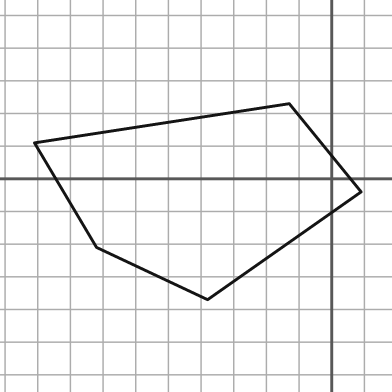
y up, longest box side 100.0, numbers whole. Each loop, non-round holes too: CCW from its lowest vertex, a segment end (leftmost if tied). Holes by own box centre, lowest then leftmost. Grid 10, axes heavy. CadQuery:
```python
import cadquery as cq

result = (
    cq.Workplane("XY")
    .moveTo(-38.0, -37.0)
    .lineTo(9.0, -4.0)
    .lineTo(-13.0, 23.0)
    .lineTo(-91.0, 11.0)
    .lineTo(-72.0, -21.0)
    .close()
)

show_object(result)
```